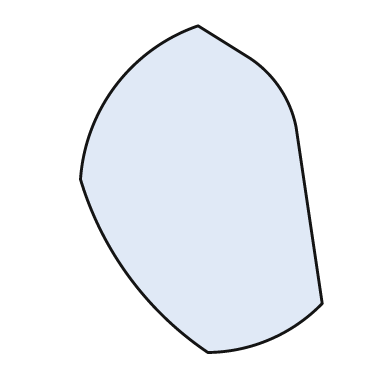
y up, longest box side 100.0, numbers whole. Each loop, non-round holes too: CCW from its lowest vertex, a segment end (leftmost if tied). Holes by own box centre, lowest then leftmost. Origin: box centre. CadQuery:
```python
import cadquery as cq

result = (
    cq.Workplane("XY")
    .moveTo(2.0, -50.0)
    .threePointArc((21.0, -46.0), (37.0, -35.0))
    .lineTo(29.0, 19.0)
    .threePointArc((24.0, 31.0), (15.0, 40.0))
    .lineTo(-1.0, 50.0)
    .threePointArc((-26.0, 32.0), (-37.0, 3.0))
    .threePointArc((-22.0, -27.0), (2.0, -50.0))
    .close()
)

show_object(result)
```